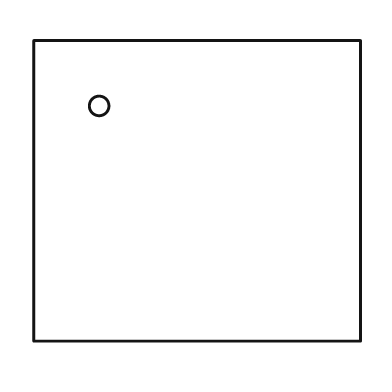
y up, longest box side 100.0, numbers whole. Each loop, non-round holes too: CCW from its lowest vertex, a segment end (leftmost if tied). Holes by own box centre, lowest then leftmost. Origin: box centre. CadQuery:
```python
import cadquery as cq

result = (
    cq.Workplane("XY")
    .moveTo(-50.0, -46.0)
    .lineTo(50.0, -46.0)
    .lineTo(50.0, 46.0)
    .lineTo(-50.0, 46.0)
    .close()
    .moveTo(-30.0, 26.0)
    .circle(3.0)
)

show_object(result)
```